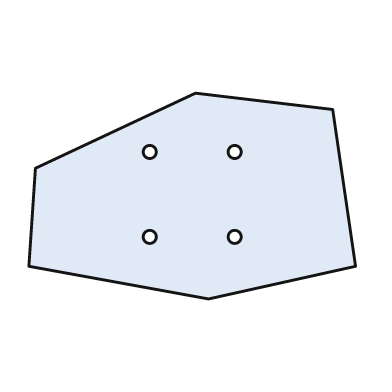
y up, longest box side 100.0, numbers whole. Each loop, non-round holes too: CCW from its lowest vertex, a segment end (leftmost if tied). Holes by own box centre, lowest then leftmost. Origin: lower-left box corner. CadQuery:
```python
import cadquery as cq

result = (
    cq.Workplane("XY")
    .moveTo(55.0, 0.0)
    .lineTo(100.0, 10.0)
    .lineTo(93.0, 58.0)
    .lineTo(51.0, 63.0)
    .lineTo(2.0, 40.0)
    .lineTo(0.0, 10.0)
    .close()
    .moveTo(37.0, 19.0)
    .circle(2.0)
    .moveTo(63.0, 19.0)
    .circle(2.0)
    .moveTo(37.0, 45.0)
    .circle(2.0)
    .moveTo(63.0, 45.0)
    .circle(2.0)
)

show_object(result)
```